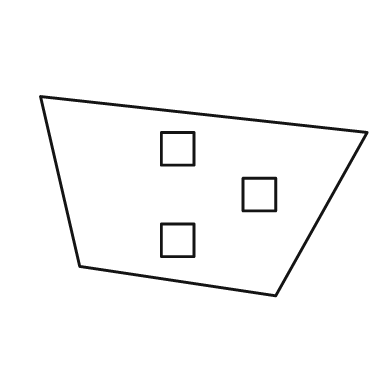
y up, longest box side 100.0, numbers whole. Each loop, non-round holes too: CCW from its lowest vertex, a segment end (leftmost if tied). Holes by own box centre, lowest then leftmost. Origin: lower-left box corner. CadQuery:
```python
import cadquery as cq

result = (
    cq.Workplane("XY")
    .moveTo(72.0, 0.0)
    .lineTo(100.0, 50.0)
    .lineTo(0.0, 61.0)
    .lineTo(12.0, 9.0)
    .close()
    .moveTo(37.0, 12.0)
    .lineTo(47.0, 12.0)
    .lineTo(47.0, 22.0)
    .lineTo(37.0, 22.0)
    .close()
    .moveTo(62.0, 26.0)
    .lineTo(72.0, 26.0)
    .lineTo(72.0, 36.0)
    .lineTo(62.0, 36.0)
    .close()
    .moveTo(37.0, 40.0)
    .lineTo(47.0, 40.0)
    .lineTo(47.0, 50.0)
    .lineTo(37.0, 50.0)
    .close()
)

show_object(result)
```